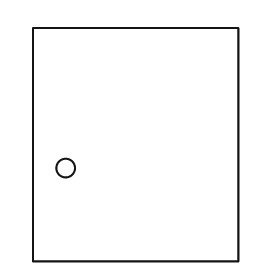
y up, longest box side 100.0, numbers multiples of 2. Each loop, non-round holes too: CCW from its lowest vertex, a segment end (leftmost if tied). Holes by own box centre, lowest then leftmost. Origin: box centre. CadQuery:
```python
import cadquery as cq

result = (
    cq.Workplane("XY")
    .moveTo(-44.0, -50.0)
    .lineTo(44.0, -50.0)
    .lineTo(44.0, 50.0)
    .lineTo(-44.0, 50.0)
    .close()
    .moveTo(-30.0, -10.0)
    .circle(4.0)
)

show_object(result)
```